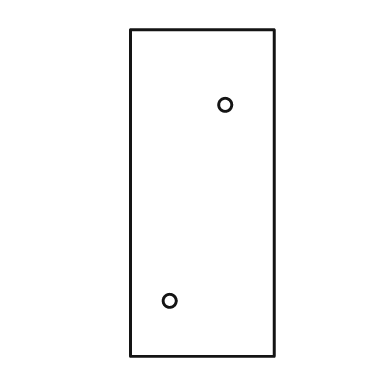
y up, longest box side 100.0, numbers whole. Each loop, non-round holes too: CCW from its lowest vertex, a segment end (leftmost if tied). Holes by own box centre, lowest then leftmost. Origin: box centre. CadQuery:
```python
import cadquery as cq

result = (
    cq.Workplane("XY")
    .moveTo(-22.0, -50.0)
    .lineTo(22.0, -50.0)
    .lineTo(22.0, 50.0)
    .lineTo(-22.0, 50.0)
    .close()
    .moveTo(-10.0, -33.0)
    .circle(2.0)
    .moveTo(7.0, 27.0)
    .circle(2.0)
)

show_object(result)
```